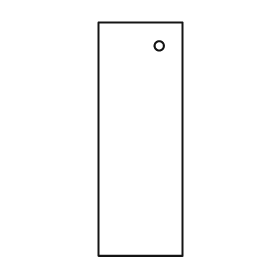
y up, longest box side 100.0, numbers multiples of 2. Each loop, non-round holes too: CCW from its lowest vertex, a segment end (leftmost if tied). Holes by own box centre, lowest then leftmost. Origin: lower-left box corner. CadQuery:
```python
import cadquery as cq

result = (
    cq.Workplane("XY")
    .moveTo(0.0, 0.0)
    .lineTo(36.0, 0.0)
    .lineTo(36.0, 100.0)
    .lineTo(0.0, 100.0)
    .close()
    .moveTo(26.0, 90.0)
    .circle(2.0)
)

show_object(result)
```